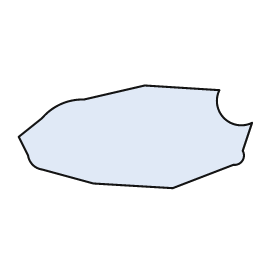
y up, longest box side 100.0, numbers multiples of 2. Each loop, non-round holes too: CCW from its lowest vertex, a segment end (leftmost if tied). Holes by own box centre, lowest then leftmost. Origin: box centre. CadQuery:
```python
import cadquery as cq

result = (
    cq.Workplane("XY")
    .moveTo(16.0, -22.0)
    .lineTo(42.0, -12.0)
    .threePointArc((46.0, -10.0), (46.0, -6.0))
    .lineTo(50.0, 6.0)
    .threePointArc((38.0, 8.0), (36.0, 20.0))
    .lineTo(4.0, 22.0)
    .lineTo(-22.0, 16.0)
    .threePointArc((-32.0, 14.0), (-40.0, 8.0))
    .lineTo(-50.0, 0.0)
    .lineTo(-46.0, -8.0)
    .threePointArc((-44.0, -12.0), (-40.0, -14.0))
    .lineTo(-18.0, -20.0)
    .close()
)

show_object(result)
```